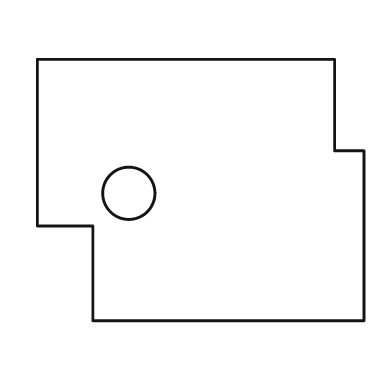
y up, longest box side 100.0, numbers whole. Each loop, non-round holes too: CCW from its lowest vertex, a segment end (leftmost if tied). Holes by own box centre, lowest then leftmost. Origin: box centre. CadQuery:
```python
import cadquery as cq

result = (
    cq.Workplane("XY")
    .moveTo(-33.0, -40.0)
    .lineTo(50.0, -40.0)
    .lineTo(50.0, 12.0)
    .lineTo(41.0, 12.0)
    .lineTo(41.0, 40.0)
    .lineTo(-50.0, 40.0)
    .lineTo(-50.0, -11.0)
    .lineTo(-33.0, -11.0)
    .close()
    .moveTo(-22.0, -1.0)
    .circle(8.0)
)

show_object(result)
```